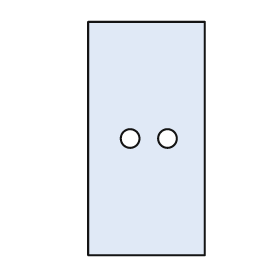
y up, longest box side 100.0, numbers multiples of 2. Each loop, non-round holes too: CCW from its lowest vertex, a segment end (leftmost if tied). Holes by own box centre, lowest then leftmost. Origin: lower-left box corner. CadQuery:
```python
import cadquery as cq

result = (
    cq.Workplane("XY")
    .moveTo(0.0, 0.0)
    .lineTo(50.0, 0.0)
    .lineTo(50.0, 100.0)
    .lineTo(0.0, 100.0)
    .close()
    .moveTo(18.0, 50.0)
    .circle(4.0)
    .moveTo(34.0, 50.0)
    .circle(4.0)
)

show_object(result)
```